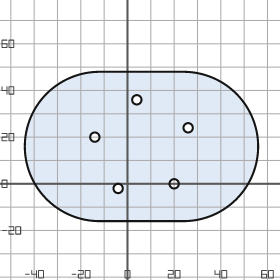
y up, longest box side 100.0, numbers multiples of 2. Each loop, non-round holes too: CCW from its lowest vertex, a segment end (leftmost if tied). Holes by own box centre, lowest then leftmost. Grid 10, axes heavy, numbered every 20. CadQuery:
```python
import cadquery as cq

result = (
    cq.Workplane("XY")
    .moveTo(-12.0, -16.0)
    .lineTo(24.0, -16.0)
    .threePointArc((56.0, 16.0), (24.0, 48.0))
    .lineTo(-12.0, 48.0)
    .threePointArc((-44.0, 16.0), (-12.0, -16.0))
    .close()
    .moveTo(-4.0, -2.0)
    .circle(2.0)
    .moveTo(20.0, 0.0)
    .circle(2.0)
    .moveTo(-14.0, 20.0)
    .circle(2.0)
    .moveTo(26.0, 24.0)
    .circle(2.0)
    .moveTo(4.0, 36.0)
    .circle(2.0)
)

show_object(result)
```